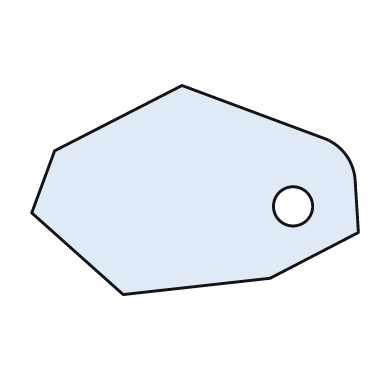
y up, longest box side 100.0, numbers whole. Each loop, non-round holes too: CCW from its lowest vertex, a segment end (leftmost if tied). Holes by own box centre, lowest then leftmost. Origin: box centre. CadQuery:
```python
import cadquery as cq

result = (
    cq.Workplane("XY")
    .moveTo(-22.0, -32.0)
    .lineTo(23.0, -27.0)
    .lineTo(50.0, -13.0)
    .lineTo(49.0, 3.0)
    .threePointArc((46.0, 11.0), (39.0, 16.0))
    .lineTo(-4.0, 32.0)
    .lineTo(-43.0, 12.0)
    .lineTo(-50.0, -7.0)
    .close()
    .moveTo(30.0, -5.0)
    .circle(6.0)
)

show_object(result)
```